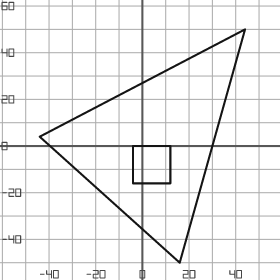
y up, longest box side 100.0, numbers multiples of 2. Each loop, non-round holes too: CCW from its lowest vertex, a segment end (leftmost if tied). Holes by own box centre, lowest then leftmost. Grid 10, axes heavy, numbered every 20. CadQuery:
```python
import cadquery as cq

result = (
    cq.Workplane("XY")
    .moveTo(16.0, -50.0)
    .lineTo(44.0, 50.0)
    .lineTo(-44.0, 4.0)
    .close()
    .moveTo(-4.0, -16.0)
    .lineTo(12.0, -16.0)
    .lineTo(12.0, 0.0)
    .lineTo(-4.0, 0.0)
    .close()
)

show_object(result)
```